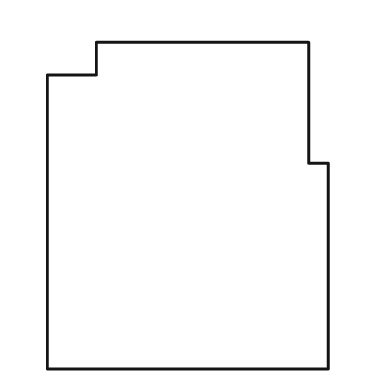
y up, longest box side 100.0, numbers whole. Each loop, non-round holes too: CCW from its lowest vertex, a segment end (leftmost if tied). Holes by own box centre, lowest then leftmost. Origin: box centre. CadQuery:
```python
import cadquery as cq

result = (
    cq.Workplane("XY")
    .moveTo(-43.0, -50.0)
    .lineTo(43.0, -50.0)
    .lineTo(43.0, 13.0)
    .lineTo(37.0, 13.0)
    .lineTo(37.0, 50.0)
    .lineTo(-28.0, 50.0)
    .lineTo(-28.0, 40.0)
    .lineTo(-43.0, 40.0)
    .close()
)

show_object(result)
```